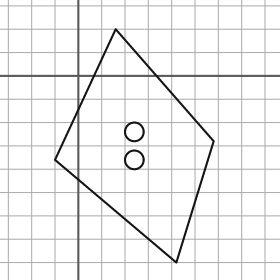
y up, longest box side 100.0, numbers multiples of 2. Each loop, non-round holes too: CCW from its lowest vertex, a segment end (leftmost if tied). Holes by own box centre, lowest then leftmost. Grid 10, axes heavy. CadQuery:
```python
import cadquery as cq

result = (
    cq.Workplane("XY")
    .moveTo(42.0, -80.0)
    .lineTo(58.0, -28.0)
    .lineTo(16.0, 20.0)
    .lineTo(-10.0, -36.0)
    .close()
    .moveTo(24.0, -36.0)
    .circle(4.0)
    .moveTo(24.0, -24.0)
    .circle(4.0)
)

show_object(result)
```